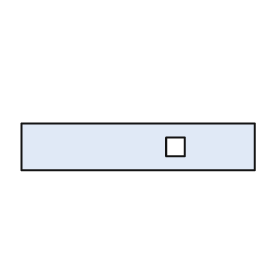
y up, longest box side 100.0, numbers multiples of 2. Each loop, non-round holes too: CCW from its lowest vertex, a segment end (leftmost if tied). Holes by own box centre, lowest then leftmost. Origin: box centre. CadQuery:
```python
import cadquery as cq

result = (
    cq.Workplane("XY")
    .moveTo(-50.0, -10.0)
    .lineTo(50.0, -10.0)
    .lineTo(50.0, 10.0)
    .lineTo(-50.0, 10.0)
    .close()
    .moveTo(12.0, -4.0)
    .lineTo(20.0, -4.0)
    .lineTo(20.0, 4.0)
    .lineTo(12.0, 4.0)
    .close()
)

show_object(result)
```